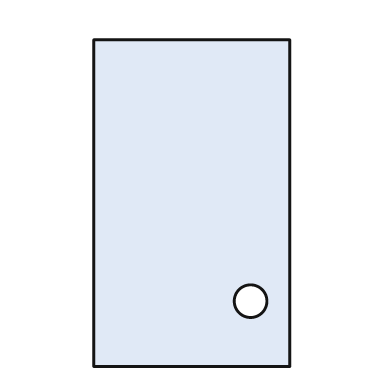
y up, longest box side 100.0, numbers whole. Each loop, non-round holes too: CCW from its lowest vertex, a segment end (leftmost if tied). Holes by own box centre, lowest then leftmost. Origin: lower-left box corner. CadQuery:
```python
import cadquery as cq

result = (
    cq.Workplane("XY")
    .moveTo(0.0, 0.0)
    .lineTo(60.0, 0.0)
    .lineTo(60.0, 100.0)
    .lineTo(0.0, 100.0)
    .close()
    .moveTo(48.0, 20.0)
    .circle(5.0)
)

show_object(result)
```